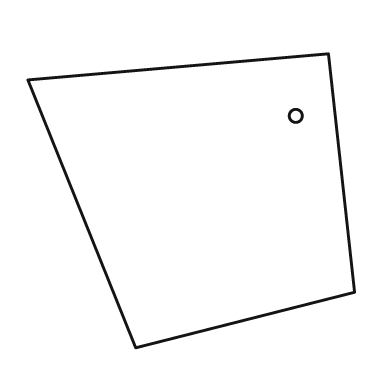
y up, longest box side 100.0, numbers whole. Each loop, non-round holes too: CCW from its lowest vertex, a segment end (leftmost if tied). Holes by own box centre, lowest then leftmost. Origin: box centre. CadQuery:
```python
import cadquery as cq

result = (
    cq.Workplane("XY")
    .moveTo(-17.0, -45.0)
    .lineTo(50.0, -28.0)
    .lineTo(42.0, 45.0)
    .lineTo(-50.0, 37.0)
    .close()
    .moveTo(32.0, 26.0)
    .circle(2.0)
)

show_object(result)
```